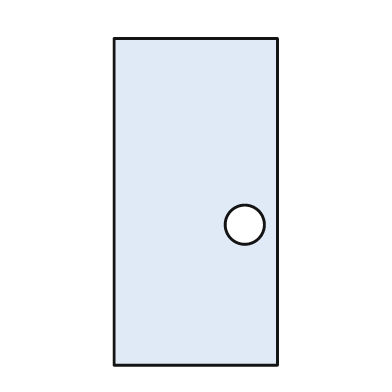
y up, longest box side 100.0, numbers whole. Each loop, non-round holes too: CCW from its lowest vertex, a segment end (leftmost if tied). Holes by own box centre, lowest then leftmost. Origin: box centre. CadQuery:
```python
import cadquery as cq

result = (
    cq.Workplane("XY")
    .moveTo(-25.0, -50.0)
    .lineTo(25.0, -50.0)
    .lineTo(25.0, 50.0)
    .lineTo(-25.0, 50.0)
    .close()
    .moveTo(15.0, -7.0)
    .circle(6.0)
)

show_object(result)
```